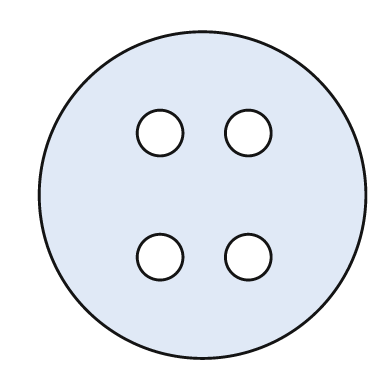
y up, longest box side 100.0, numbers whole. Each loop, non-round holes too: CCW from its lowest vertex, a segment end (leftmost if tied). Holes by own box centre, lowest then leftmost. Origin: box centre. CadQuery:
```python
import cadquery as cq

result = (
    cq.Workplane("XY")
    .moveTo(0.0, 0.0)
    .circle(50.0)
    .moveTo(-13.0, -19.0)
    .circle(7.0)
    .moveTo(14.0, -19.0)
    .circle(7.0)
    .moveTo(-13.0, 19.0)
    .circle(7.0)
    .moveTo(14.0, 19.0)
    .circle(7.0)
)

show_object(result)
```